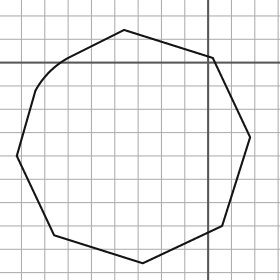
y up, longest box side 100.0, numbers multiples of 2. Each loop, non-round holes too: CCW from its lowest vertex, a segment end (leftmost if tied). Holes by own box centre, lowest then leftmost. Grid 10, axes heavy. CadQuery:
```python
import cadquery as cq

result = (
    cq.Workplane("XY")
    .moveTo(-28.0, -86.0)
    .lineTo(6.0, -70.0)
    .lineTo(18.0, -32.0)
    .lineTo(2.0, 2.0)
    .lineTo(-36.0, 14.0)
    .lineTo(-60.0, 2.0)
    .threePointArc((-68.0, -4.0), (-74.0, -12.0))
    .lineTo(-82.0, -40.0)
    .lineTo(-66.0, -74.0)
    .close()
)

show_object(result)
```